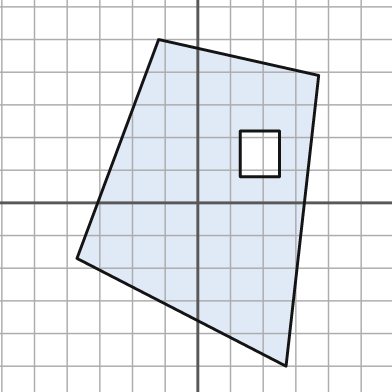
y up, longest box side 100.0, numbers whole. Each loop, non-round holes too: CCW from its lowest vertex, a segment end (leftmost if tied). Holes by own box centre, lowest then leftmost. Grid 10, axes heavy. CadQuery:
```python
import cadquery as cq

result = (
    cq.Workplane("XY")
    .moveTo(27.0, -50.0)
    .lineTo(37.0, 39.0)
    .lineTo(-12.0, 50.0)
    .lineTo(-37.0, -17.0)
    .close()
    .moveTo(13.0, 8.0)
    .lineTo(25.0, 8.0)
    .lineTo(25.0, 22.0)
    .lineTo(13.0, 22.0)
    .close()
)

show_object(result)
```